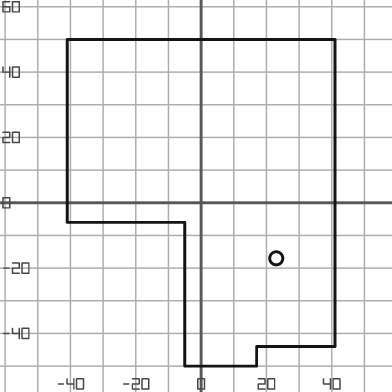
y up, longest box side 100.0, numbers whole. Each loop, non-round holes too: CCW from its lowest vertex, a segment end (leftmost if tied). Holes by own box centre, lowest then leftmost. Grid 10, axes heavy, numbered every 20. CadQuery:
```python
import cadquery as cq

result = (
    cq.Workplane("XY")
    .moveTo(-5.0, -50.0)
    .lineTo(17.0, -50.0)
    .lineTo(17.0, -44.0)
    .lineTo(41.0, -44.0)
    .lineTo(41.0, 50.0)
    .lineTo(-41.0, 50.0)
    .lineTo(-41.0, -6.0)
    .lineTo(-5.0, -6.0)
    .close()
    .moveTo(23.0, -17.0)
    .circle(2.0)
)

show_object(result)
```